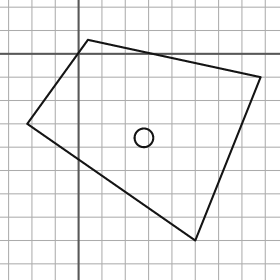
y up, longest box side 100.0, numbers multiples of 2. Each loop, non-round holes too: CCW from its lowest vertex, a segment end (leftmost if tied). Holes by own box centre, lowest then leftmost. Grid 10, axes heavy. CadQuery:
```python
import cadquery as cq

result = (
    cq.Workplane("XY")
    .moveTo(50.0, -80.0)
    .lineTo(78.0, -10.0)
    .lineTo(4.0, 6.0)
    .lineTo(-22.0, -30.0)
    .close()
    .moveTo(28.0, -36.0)
    .circle(4.0)
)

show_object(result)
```